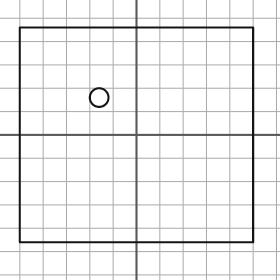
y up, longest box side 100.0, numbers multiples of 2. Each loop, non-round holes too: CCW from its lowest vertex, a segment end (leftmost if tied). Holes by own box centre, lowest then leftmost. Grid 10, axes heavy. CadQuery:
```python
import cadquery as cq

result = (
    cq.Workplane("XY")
    .moveTo(-50.0, -46.0)
    .lineTo(50.0, -46.0)
    .lineTo(50.0, 46.0)
    .lineTo(-50.0, 46.0)
    .close()
    .moveTo(-16.0, 16.0)
    .circle(4.0)
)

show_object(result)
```